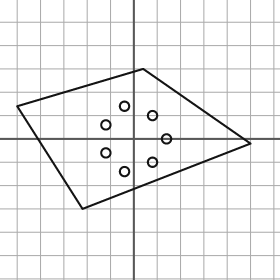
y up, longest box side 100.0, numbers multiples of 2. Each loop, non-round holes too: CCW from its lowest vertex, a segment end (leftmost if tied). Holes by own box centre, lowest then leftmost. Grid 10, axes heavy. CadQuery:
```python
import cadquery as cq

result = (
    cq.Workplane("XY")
    .moveTo(-22.0, -30.0)
    .lineTo(50.0, -2.0)
    .lineTo(4.0, 30.0)
    .lineTo(-50.0, 14.0)
    .close()
    .moveTo(-4.0, -14.0)
    .circle(2.0)
    .moveTo(8.0, -10.0)
    .circle(2.0)
    .moveTo(-12.0, -6.0)
    .circle(2.0)
    .moveTo(14.0, 0.0)
    .circle(2.0)
    .moveTo(-12.0, 6.0)
    .circle(2.0)
    .moveTo(8.0, 10.0)
    .circle(2.0)
    .moveTo(-4.0, 14.0)
    .circle(2.0)
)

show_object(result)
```